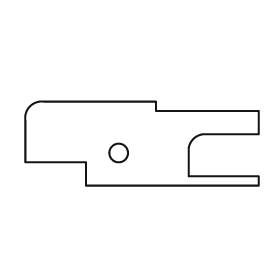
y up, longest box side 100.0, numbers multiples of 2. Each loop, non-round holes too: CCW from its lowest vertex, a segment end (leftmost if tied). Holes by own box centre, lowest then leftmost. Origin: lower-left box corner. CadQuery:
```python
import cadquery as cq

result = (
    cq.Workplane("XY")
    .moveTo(26.0, 0.0)
    .lineTo(100.0, 0.0)
    .lineTo(100.0, 4.0)
    .lineTo(70.0, 4.0)
    .lineTo(70.0, 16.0)
    .threePointArc((72.0, 20.0), (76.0, 22.0))
    .lineTo(100.0, 22.0)
    .lineTo(100.0, 32.0)
    .lineTo(56.0, 32.0)
    .lineTo(56.0, 36.0)
    .lineTo(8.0, 36.0)
    .threePointArc((2.0, 34.0), (0.0, 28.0))
    .lineTo(0.0, 10.0)
    .lineTo(26.0, 10.0)
    .close()
    .moveTo(40.0, 14.0)
    .circle(4.0)
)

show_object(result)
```